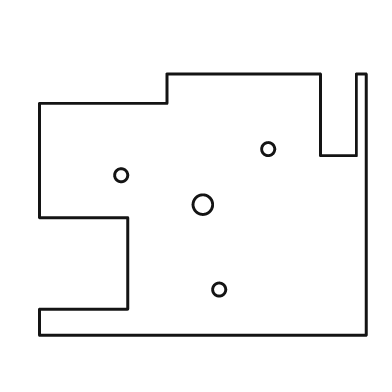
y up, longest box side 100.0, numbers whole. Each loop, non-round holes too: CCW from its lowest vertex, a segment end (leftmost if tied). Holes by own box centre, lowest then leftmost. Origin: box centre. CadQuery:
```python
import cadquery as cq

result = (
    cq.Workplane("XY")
    .moveTo(-50.0, -40.0)
    .lineTo(50.0, -40.0)
    .lineTo(50.0, 40.0)
    .lineTo(47.0, 40.0)
    .lineTo(47.0, 15.0)
    .lineTo(36.0, 15.0)
    .lineTo(36.0, 40.0)
    .lineTo(-11.0, 40.0)
    .lineTo(-11.0, 31.0)
    .lineTo(-50.0, 31.0)
    .lineTo(-50.0, -4.0)
    .lineTo(-23.0, -4.0)
    .lineTo(-23.0, -32.0)
    .lineTo(-50.0, -32.0)
    .close()
    .moveTo(5.0, -26.0)
    .circle(2.0)
    .moveTo(0.0, 0.0)
    .circle(3.0)
    .moveTo(-25.0, 9.0)
    .circle(2.0)
    .moveTo(20.0, 17.0)
    .circle(2.0)
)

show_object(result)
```